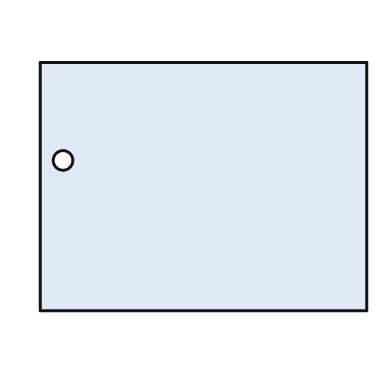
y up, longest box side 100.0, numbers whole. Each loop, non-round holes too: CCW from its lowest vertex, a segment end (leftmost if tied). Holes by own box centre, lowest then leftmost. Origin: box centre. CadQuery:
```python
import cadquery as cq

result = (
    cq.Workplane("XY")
    .moveTo(-50.0, -38.0)
    .lineTo(50.0, -38.0)
    .lineTo(50.0, 38.0)
    .lineTo(-50.0, 38.0)
    .close()
    .moveTo(-43.0, 8.0)
    .circle(3.0)
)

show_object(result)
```